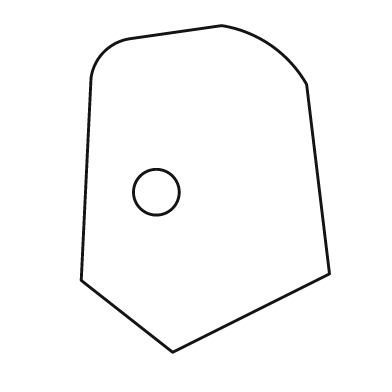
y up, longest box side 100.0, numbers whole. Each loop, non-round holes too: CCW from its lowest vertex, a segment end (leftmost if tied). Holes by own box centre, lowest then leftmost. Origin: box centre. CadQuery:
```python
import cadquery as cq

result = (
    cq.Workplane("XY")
    .moveTo(-10.0, -50.0)
    .lineTo(38.0, -26.0)
    .lineTo(31.0, 32.0)
    .threePointArc((20.0, 44.0), (5.0, 50.0))
    .lineTo(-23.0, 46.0)
    .threePointArc((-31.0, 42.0), (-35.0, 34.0))
    .lineTo(-38.0, -28.0)
    .close()
    .moveTo(-15.0, -1.0)
    .circle(7.0)
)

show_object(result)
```